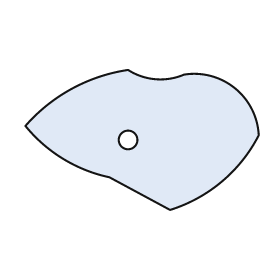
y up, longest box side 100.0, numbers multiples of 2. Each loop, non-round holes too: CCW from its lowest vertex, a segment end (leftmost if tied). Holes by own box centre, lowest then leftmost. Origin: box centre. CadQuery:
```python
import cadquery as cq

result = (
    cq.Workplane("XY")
    .moveTo(12.0, -30.0)
    .threePointArc((34.0, -18.0), (50.0, 2.0))
    .threePointArc((40.0, 22.0), (18.0, 28.0))
    .threePointArc((6.0, 26.0), (-6.0, 30.0))
    .threePointArc((-30.0, 22.0), (-50.0, 6.0))
    .threePointArc((-34.0, -8.0), (-14.0, -16.0))
    .close()
    .moveTo(-6.0, 0.0)
    .circle(4.0)
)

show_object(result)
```